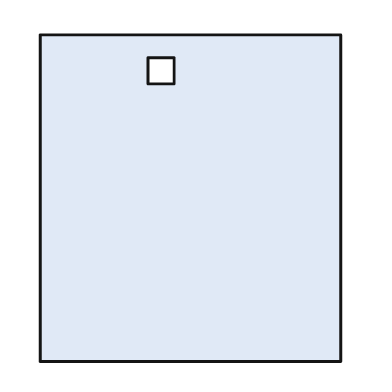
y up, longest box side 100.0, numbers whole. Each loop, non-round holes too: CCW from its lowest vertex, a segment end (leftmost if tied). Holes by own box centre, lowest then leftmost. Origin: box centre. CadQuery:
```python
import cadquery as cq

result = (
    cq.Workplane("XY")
    .moveTo(-46.0, -50.0)
    .lineTo(46.0, -50.0)
    .lineTo(46.0, 50.0)
    .lineTo(-46.0, 50.0)
    .close()
    .moveTo(-13.0, 35.0)
    .lineTo(-5.0, 35.0)
    .lineTo(-5.0, 43.0)
    .lineTo(-13.0, 43.0)
    .close()
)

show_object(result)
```